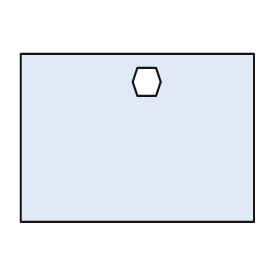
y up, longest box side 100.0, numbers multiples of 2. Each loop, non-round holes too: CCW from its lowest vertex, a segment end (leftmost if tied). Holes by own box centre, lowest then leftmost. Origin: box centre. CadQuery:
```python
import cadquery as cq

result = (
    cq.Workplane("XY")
    .moveTo(-50.0, -36.0)
    .lineTo(50.0, -36.0)
    .lineTo(50.0, 36.0)
    .lineTo(-50.0, 36.0)
    .close()
    .moveTo(0.0, 18.0)
    .lineTo(8.0, 18.0)
    .lineTo(10.0, 24.0)
    .lineTo(8.0, 30.0)
    .lineTo(0.0, 30.0)
    .lineTo(-2.0, 24.0)
    .close()
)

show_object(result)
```